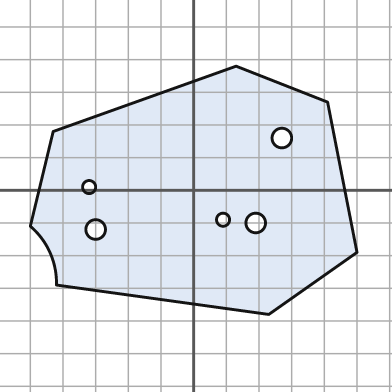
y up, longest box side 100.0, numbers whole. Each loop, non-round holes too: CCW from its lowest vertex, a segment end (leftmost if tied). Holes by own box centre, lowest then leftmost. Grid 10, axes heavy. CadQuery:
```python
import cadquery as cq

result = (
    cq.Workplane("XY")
    .moveTo(23.0, -38.0)
    .lineTo(50.0, -19.0)
    .lineTo(41.0, 27.0)
    .lineTo(13.0, 38.0)
    .lineTo(-43.0, 18.0)
    .lineTo(-50.0, -11.0)
    .threePointArc((-44.0, -19.0), (-42.0, -29.0))
    .close()
    .moveTo(-30.0, -12.0)
    .circle(3.0)
    .moveTo(19.0, -10.0)
    .circle(3.0)
    .moveTo(9.0, -9.0)
    .circle(2.0)
    .moveTo(-32.0, 1.0)
    .circle(2.0)
    .moveTo(27.0, 16.0)
    .circle(3.0)
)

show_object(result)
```